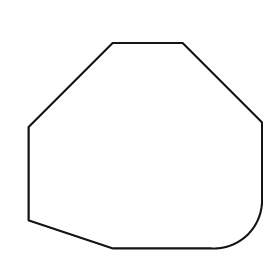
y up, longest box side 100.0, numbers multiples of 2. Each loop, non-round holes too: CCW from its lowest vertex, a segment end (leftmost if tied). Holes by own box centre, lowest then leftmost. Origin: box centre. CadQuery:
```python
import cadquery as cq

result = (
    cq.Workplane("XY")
    .moveTo(-14.0, -44.0)
    .lineTo(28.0, -44.0)
    .threePointArc((44.0, -38.0), (50.0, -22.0))
    .lineTo(50.0, 10.0)
    .lineTo(16.0, 44.0)
    .lineTo(-14.0, 44.0)
    .lineTo(-50.0, 8.0)
    .lineTo(-50.0, -32.0)
    .close()
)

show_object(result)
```